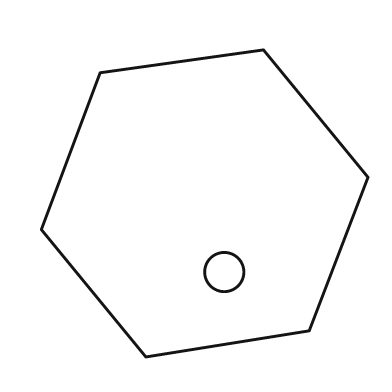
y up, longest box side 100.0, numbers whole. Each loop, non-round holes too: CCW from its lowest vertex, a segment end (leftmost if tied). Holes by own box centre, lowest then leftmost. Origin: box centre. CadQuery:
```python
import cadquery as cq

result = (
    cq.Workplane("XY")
    .moveTo(-18.0, -47.0)
    .lineTo(32.0, -39.0)
    .lineTo(50.0, 8.0)
    .lineTo(18.0, 47.0)
    .lineTo(-32.0, 40.0)
    .lineTo(-50.0, -8.0)
    .close()
    .moveTo(6.0, -21.0)
    .circle(6.0)
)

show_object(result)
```